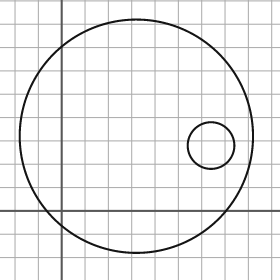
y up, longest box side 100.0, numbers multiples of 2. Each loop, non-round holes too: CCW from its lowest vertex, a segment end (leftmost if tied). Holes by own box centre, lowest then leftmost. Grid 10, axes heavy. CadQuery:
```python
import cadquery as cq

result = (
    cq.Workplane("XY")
    .moveTo(32.0, 32.0)
    .circle(50.0)
    .moveTo(64.0, 28.0)
    .circle(10.0)
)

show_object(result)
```